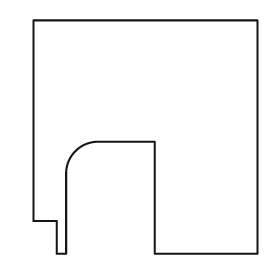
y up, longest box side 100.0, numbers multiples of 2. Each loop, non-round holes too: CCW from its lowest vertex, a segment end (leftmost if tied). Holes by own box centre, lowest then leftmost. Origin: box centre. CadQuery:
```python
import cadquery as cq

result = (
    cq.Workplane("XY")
    .moveTo(-38.0, -50.0)
    .lineTo(-34.0, -50.0)
    .lineTo(-34.0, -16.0)
    .threePointArc((-30.0, -6.0), (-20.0, -2.0))
    .lineTo(4.0, -2.0)
    .lineTo(4.0, -50.0)
    .lineTo(48.0, -50.0)
    .lineTo(48.0, 50.0)
    .lineTo(-48.0, 50.0)
    .lineTo(-48.0, -36.0)
    .lineTo(-38.0, -36.0)
    .close()
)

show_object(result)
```